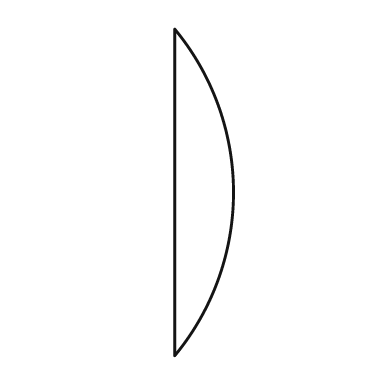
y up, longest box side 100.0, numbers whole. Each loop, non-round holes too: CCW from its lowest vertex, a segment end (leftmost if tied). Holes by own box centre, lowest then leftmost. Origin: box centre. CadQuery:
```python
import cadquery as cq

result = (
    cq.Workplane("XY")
    .moveTo(-9.0, -50.0)
    .threePointArc((9.0, 0.0), (-9.0, 50.0))
    .close()
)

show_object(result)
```